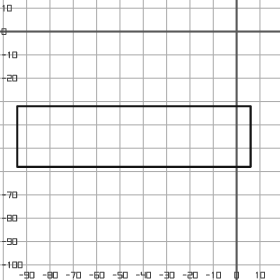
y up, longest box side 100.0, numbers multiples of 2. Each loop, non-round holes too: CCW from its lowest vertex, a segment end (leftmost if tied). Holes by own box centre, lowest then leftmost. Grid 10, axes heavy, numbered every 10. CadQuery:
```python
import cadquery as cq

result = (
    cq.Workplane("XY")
    .moveTo(-94.0, -58.0)
    .lineTo(6.0, -58.0)
    .lineTo(6.0, -32.0)
    .lineTo(-94.0, -32.0)
    .close()
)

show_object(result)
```